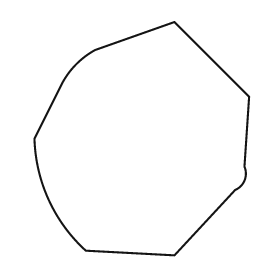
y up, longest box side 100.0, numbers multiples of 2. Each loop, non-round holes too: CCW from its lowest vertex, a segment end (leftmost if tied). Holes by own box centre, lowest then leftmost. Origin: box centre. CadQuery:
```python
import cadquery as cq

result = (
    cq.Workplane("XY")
    .moveTo(14.0, -50.0)
    .lineTo(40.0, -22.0)
    .threePointArc((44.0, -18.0), (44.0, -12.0))
    .lineTo(46.0, 18.0)
    .lineTo(14.0, 50.0)
    .lineTo(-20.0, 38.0)
    .threePointArc((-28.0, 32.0), (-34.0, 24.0))
    .lineTo(-46.0, 0.0)
    .threePointArc((-40.0, -26.0), (-24.0, -48.0))
    .close()
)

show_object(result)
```